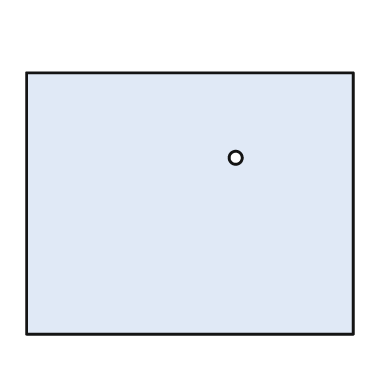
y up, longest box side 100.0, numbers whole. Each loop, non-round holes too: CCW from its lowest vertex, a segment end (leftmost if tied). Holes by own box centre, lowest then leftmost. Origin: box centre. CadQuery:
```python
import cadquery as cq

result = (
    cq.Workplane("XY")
    .moveTo(-50.0, -40.0)
    .lineTo(50.0, -40.0)
    .lineTo(50.0, 40.0)
    .lineTo(-50.0, 40.0)
    .close()
    .moveTo(14.0, 14.0)
    .circle(2.0)
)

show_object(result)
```